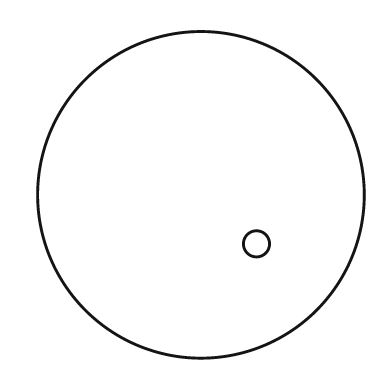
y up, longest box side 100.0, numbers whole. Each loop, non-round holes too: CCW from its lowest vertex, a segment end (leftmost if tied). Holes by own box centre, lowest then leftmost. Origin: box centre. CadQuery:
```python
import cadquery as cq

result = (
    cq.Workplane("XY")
    .moveTo(0.0, 0.0)
    .circle(50.0)
    .moveTo(17.0, -15.0)
    .circle(4.0)
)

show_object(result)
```